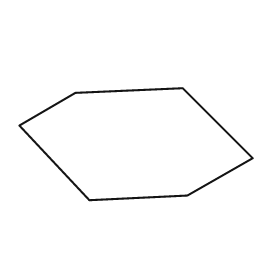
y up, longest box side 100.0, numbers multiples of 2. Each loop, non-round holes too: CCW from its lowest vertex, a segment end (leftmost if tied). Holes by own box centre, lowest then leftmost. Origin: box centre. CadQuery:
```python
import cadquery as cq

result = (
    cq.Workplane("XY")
    .moveTo(-20.0, -24.0)
    .lineTo(22.0, -22.0)
    .lineTo(50.0, -6.0)
    .lineTo(20.0, 24.0)
    .lineTo(-26.0, 22.0)
    .lineTo(-50.0, 8.0)
    .close()
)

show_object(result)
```